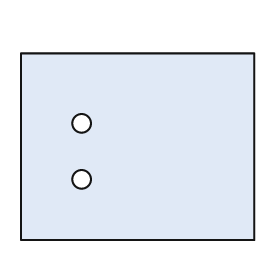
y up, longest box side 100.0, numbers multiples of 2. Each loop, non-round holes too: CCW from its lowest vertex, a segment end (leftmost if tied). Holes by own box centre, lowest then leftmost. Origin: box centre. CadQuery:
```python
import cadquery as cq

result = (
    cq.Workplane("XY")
    .moveTo(-50.0, -40.0)
    .lineTo(50.0, -40.0)
    .lineTo(50.0, 40.0)
    .lineTo(-50.0, 40.0)
    .close()
    .moveTo(-24.0, -14.0)
    .circle(4.0)
    .moveTo(-24.0, 10.0)
    .circle(4.0)
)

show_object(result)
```